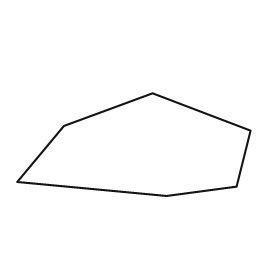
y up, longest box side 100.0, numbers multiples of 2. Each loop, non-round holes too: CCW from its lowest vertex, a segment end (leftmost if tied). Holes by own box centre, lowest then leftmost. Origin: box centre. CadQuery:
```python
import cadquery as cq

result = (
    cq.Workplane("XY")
    .moveTo(14.0, -22.0)
    .lineTo(44.0, -18.0)
    .lineTo(50.0, 6.0)
    .lineTo(8.0, 22.0)
    .lineTo(-30.0, 8.0)
    .lineTo(-50.0, -16.0)
    .close()
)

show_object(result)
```